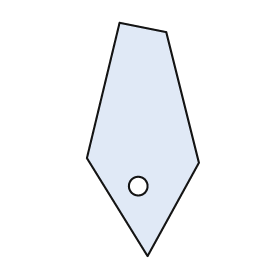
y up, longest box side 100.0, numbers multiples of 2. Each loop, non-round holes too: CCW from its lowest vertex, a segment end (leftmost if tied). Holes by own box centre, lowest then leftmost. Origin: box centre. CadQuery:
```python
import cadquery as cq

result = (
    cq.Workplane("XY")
    .moveTo(2.0, -50.0)
    .lineTo(24.0, -10.0)
    .lineTo(10.0, 46.0)
    .lineTo(-10.0, 50.0)
    .lineTo(-24.0, -8.0)
    .close()
    .moveTo(-2.0, -20.0)
    .circle(4.0)
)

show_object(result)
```